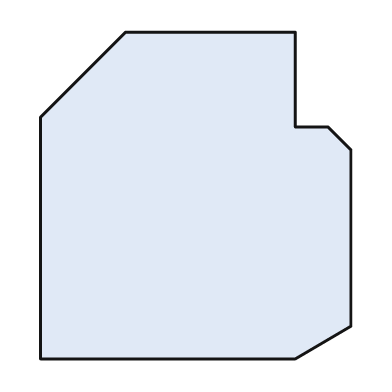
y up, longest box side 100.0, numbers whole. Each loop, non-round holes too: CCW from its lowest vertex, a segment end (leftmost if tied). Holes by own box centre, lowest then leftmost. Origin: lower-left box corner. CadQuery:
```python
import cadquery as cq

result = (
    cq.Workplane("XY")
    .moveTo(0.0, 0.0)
    .lineTo(78.0, 0.0)
    .lineTo(95.0, 10.0)
    .lineTo(95.0, 64.0)
    .lineTo(88.0, 71.0)
    .lineTo(78.0, 71.0)
    .lineTo(78.0, 100.0)
    .lineTo(26.0, 100.0)
    .lineTo(0.0, 74.0)
    .close()
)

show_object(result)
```